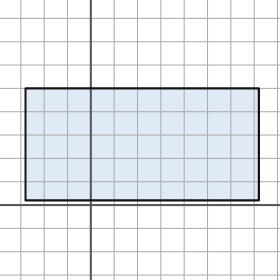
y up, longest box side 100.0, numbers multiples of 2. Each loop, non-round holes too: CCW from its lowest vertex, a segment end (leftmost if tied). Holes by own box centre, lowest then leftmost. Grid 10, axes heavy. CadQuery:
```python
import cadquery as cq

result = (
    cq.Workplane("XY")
    .moveTo(-28.0, 2.0)
    .lineTo(72.0, 2.0)
    .lineTo(72.0, 50.0)
    .lineTo(-28.0, 50.0)
    .close()
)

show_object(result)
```